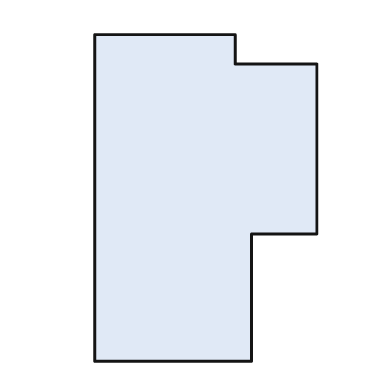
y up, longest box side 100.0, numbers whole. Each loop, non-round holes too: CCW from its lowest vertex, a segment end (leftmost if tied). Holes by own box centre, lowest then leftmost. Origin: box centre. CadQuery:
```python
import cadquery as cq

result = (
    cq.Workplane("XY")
    .moveTo(-34.0, -50.0)
    .lineTo(14.0, -50.0)
    .lineTo(14.0, -11.0)
    .lineTo(34.0, -11.0)
    .lineTo(34.0, 41.0)
    .lineTo(9.0, 41.0)
    .lineTo(9.0, 50.0)
    .lineTo(-34.0, 50.0)
    .close()
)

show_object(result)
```